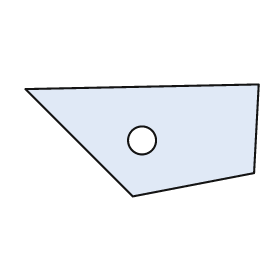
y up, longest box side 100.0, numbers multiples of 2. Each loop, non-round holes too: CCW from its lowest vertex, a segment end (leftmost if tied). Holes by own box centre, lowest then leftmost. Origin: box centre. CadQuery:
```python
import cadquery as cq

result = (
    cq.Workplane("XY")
    .moveTo(-4.0, -24.0)
    .lineTo(48.0, -14.0)
    .lineTo(50.0, 24.0)
    .lineTo(-50.0, 22.0)
    .close()
    .moveTo(0.0, 0.0)
    .circle(6.0)
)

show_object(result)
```